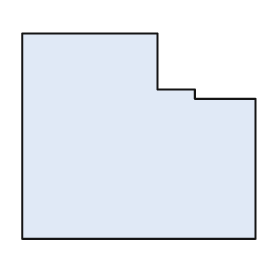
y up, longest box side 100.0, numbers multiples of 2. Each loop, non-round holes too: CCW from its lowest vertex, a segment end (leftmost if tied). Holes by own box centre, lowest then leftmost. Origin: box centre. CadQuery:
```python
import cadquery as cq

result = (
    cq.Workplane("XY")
    .moveTo(-50.0, -44.0)
    .lineTo(50.0, -44.0)
    .lineTo(50.0, 16.0)
    .lineTo(24.0, 16.0)
    .lineTo(24.0, 20.0)
    .lineTo(8.0, 20.0)
    .lineTo(8.0, 44.0)
    .lineTo(-50.0, 44.0)
    .close()
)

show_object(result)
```